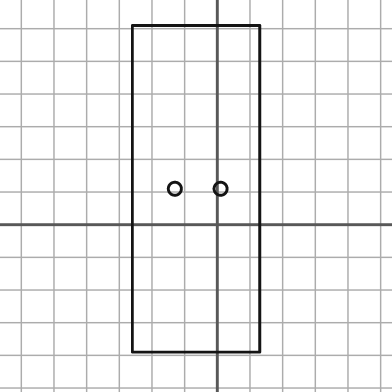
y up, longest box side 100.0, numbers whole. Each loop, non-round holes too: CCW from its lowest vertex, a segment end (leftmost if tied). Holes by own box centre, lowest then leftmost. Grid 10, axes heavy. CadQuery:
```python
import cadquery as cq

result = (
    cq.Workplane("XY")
    .moveTo(-26.0, -39.0)
    .lineTo(13.0, -39.0)
    .lineTo(13.0, 61.0)
    .lineTo(-26.0, 61.0)
    .close()
    .moveTo(-13.0, 11.0)
    .circle(2.0)
    .moveTo(1.0, 11.0)
    .circle(2.0)
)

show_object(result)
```